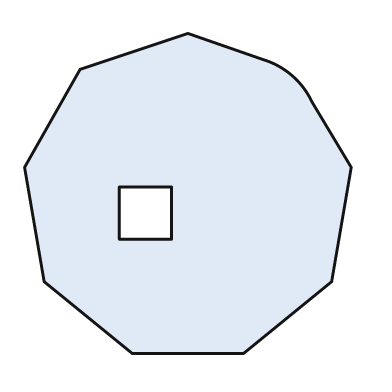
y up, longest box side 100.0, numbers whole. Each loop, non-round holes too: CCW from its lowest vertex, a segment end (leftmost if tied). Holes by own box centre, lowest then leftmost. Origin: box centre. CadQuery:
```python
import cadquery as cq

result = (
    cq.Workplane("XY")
    .moveTo(-17.0, -49.0)
    .lineTo(17.0, -49.0)
    .lineTo(44.0, -27.0)
    .lineTo(50.0, 8.0)
    .lineTo(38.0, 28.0)
    .threePointArc((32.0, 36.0), (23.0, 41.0))
    .lineTo(0.0, 49.0)
    .lineTo(-33.0, 38.0)
    .lineTo(-50.0, 8.0)
    .lineTo(-44.0, -27.0)
    .close()
    .moveTo(-21.0, -14.0)
    .lineTo(-5.0, -14.0)
    .lineTo(-5.0, 2.0)
    .lineTo(-21.0, 2.0)
    .close()
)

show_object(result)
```